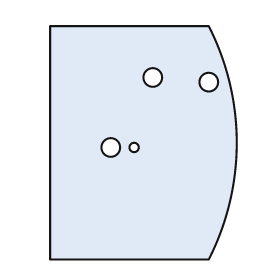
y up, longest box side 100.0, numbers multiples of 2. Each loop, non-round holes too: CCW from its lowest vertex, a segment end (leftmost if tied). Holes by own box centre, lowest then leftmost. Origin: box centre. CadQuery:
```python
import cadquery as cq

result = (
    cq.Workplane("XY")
    .moveTo(-40.0, -50.0)
    .lineTo(28.0, -50.0)
    .threePointArc((40.0, 0.0), (28.0, 50.0))
    .lineTo(-40.0, 50.0)
    .close()
    .moveTo(-14.0, -2.0)
    .circle(4.0)
    .moveTo(-4.0, -2.0)
    .circle(2.0)
    .moveTo(28.0, 26.0)
    .circle(4.0)
    .moveTo(4.0, 28.0)
    .circle(4.0)
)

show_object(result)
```